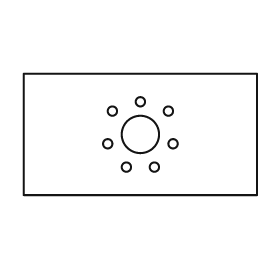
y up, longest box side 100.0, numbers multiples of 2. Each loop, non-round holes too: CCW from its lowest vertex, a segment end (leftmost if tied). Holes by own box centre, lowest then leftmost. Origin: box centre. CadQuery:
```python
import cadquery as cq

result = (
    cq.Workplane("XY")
    .moveTo(-50.0, -26.0)
    .lineTo(50.0, -26.0)
    .lineTo(50.0, 26.0)
    .lineTo(-50.0, 26.0)
    .close()
    .moveTo(-6.0, -14.0)
    .circle(2.0)
    .moveTo(6.0, -14.0)
    .circle(2.0)
    .moveTo(-14.0, -4.0)
    .circle(2.0)
    .moveTo(14.0, -4.0)
    .circle(2.0)
    .moveTo(0.0, 0.0)
    .circle(8.0)
    .moveTo(-12.0, 10.0)
    .circle(2.0)
    .moveTo(12.0, 10.0)
    .circle(2.0)
    .moveTo(0.0, 14.0)
    .circle(2.0)
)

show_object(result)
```